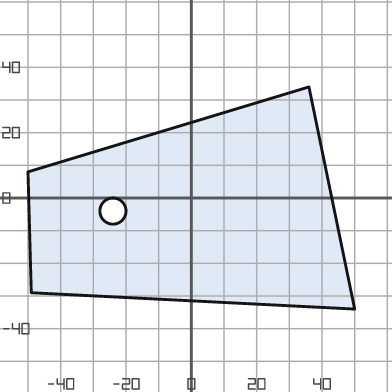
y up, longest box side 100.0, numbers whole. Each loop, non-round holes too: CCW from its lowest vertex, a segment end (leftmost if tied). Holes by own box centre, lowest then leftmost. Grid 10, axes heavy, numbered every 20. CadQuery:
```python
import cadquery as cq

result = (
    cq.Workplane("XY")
    .moveTo(50.0, -34.0)
    .lineTo(36.0, 34.0)
    .lineTo(-50.0, 8.0)
    .lineTo(-49.0, -29.0)
    .close()
    .moveTo(-24.0, -4.0)
    .circle(4.0)
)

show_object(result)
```